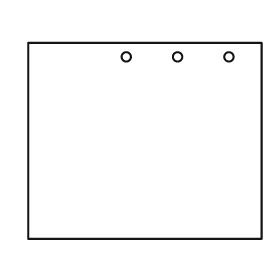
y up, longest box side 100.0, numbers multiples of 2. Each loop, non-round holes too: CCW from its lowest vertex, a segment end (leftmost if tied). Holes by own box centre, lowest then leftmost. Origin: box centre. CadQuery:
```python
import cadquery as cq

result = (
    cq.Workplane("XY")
    .moveTo(-50.0, -42.0)
    .lineTo(50.0, -42.0)
    .lineTo(50.0, 42.0)
    .lineTo(-50.0, 42.0)
    .close()
    .moveTo(-8.0, 36.0)
    .circle(2.0)
    .moveTo(14.0, 36.0)
    .circle(2.0)
    .moveTo(36.0, 36.0)
    .circle(2.0)
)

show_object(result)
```